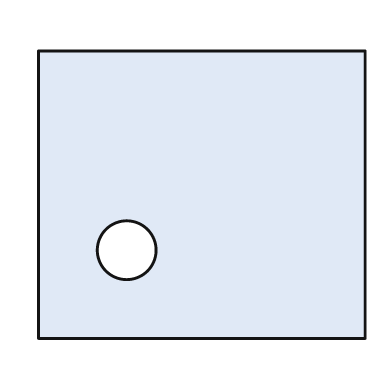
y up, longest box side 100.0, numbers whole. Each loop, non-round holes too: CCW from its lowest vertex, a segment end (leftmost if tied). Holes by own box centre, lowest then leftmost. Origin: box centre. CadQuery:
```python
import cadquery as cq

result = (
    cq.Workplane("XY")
    .moveTo(-50.0, -44.0)
    .lineTo(50.0, -44.0)
    .lineTo(50.0, 44.0)
    .lineTo(-50.0, 44.0)
    .close()
    .moveTo(-23.0, -17.0)
    .circle(9.0)
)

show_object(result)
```